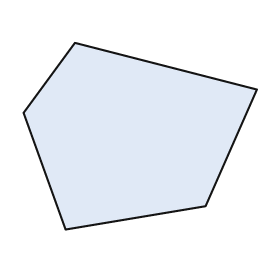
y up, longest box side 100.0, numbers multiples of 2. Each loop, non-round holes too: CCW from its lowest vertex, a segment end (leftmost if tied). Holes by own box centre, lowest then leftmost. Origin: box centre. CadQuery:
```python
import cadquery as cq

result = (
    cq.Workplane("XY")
    .moveTo(-32.0, -40.0)
    .lineTo(28.0, -30.0)
    .lineTo(50.0, 20.0)
    .lineTo(-28.0, 40.0)
    .lineTo(-50.0, 10.0)
    .close()
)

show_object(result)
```